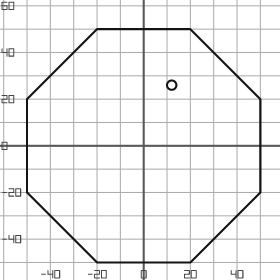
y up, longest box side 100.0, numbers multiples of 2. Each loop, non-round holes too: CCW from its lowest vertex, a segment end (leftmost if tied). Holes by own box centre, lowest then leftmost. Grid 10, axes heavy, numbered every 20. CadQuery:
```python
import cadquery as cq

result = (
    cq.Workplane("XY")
    .moveTo(-20.0, -50.0)
    .lineTo(20.0, -50.0)
    .lineTo(50.0, -20.0)
    .lineTo(50.0, 20.0)
    .lineTo(20.0, 50.0)
    .lineTo(-20.0, 50.0)
    .lineTo(-50.0, 20.0)
    .lineTo(-50.0, -20.0)
    .close()
    .moveTo(12.0, 26.0)
    .circle(2.0)
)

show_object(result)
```